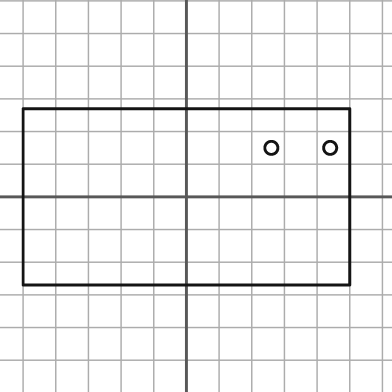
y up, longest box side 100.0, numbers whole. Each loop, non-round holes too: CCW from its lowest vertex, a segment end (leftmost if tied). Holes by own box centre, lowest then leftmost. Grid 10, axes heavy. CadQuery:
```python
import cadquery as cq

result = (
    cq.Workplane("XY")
    .moveTo(-50.0, -27.0)
    .lineTo(50.0, -27.0)
    .lineTo(50.0, 27.0)
    .lineTo(-50.0, 27.0)
    .close()
    .moveTo(26.0, 15.0)
    .circle(2.0)
    .moveTo(44.0, 15.0)
    .circle(2.0)
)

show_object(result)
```